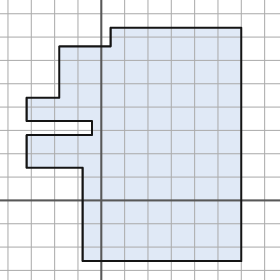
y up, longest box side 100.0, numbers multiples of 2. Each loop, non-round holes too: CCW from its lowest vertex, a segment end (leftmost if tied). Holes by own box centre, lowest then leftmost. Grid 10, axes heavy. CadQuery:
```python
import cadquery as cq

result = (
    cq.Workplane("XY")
    .moveTo(-8.0, -26.0)
    .lineTo(60.0, -26.0)
    .lineTo(60.0, 74.0)
    .lineTo(4.0, 74.0)
    .lineTo(4.0, 66.0)
    .lineTo(-18.0, 66.0)
    .lineTo(-18.0, 44.0)
    .lineTo(-32.0, 44.0)
    .lineTo(-32.0, 34.0)
    .lineTo(-4.0, 34.0)
    .lineTo(-4.0, 28.0)
    .lineTo(-32.0, 28.0)
    .lineTo(-32.0, 14.0)
    .lineTo(-8.0, 14.0)
    .close()
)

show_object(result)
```